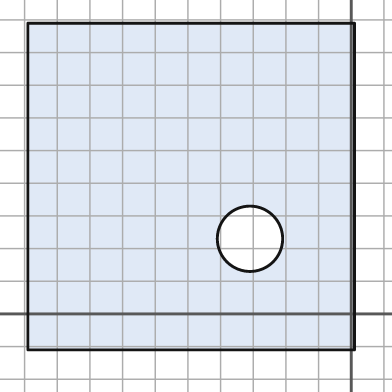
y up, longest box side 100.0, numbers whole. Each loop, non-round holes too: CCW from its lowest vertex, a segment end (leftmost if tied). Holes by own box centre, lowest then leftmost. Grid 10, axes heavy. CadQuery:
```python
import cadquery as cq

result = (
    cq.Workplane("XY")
    .moveTo(-99.0, -11.0)
    .lineTo(1.0, -11.0)
    .lineTo(1.0, 89.0)
    .lineTo(-99.0, 89.0)
    .close()
    .moveTo(-31.0, 23.0)
    .circle(10.0)
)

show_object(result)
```